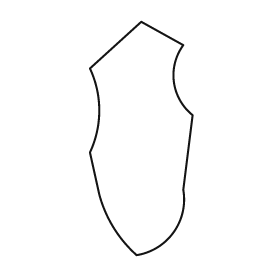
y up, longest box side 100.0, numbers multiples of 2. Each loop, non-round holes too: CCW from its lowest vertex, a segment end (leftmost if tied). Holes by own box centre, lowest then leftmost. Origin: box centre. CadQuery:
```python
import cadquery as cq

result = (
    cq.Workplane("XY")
    .moveTo(-2.0, -50.0)
    .threePointArc((14.0, -40.0), (18.0, -22.0))
    .lineTo(22.0, 10.0)
    .threePointArc((14.0, 24.0), (18.0, 40.0))
    .lineTo(0.0, 50.0)
    .lineTo(-22.0, 30.0)
    .threePointArc((-18.0, 12.0), (-22.0, -6.0))
    .lineTo(-18.0, -24.0)
    .threePointArc((-12.0, -38.0), (-2.0, -50.0))
    .close()
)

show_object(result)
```